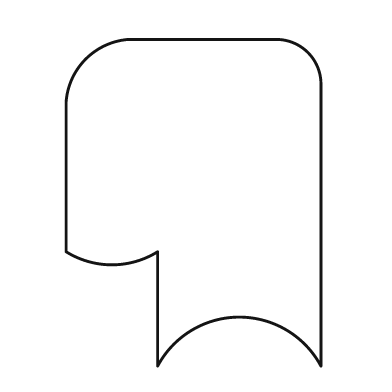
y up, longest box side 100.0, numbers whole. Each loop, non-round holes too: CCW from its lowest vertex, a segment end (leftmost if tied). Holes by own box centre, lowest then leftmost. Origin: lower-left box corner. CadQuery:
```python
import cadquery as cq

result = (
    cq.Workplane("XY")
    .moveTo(28.0, 0.0)
    .threePointArc((53.0, 15.0), (78.0, 0.0))
    .lineTo(78.0, 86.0)
    .threePointArc((74.0, 96.0), (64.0, 100.0))
    .lineTo(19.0, 100.0)
    .threePointArc((6.0, 94.0), (0.0, 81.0))
    .lineTo(0.0, 35.0)
    .threePointArc((14.0, 31.0), (28.0, 35.0))
    .close()
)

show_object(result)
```